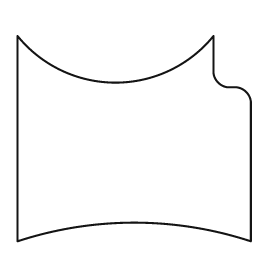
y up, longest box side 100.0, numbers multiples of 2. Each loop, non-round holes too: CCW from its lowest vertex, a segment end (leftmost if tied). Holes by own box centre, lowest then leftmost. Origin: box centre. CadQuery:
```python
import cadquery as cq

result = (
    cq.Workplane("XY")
    .moveTo(-50.0, -44.0)
    .threePointArc((0.0, -36.0), (50.0, -44.0))
    .lineTo(50.0, 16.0)
    .threePointArc((48.0, 20.0), (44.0, 22.0))
    .lineTo(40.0, 22.0)
    .threePointArc((36.0, 24.0), (34.0, 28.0))
    .lineTo(34.0, 44.0)
    .threePointArc((-8.0, 24.0), (-50.0, 44.0))
    .close()
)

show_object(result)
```